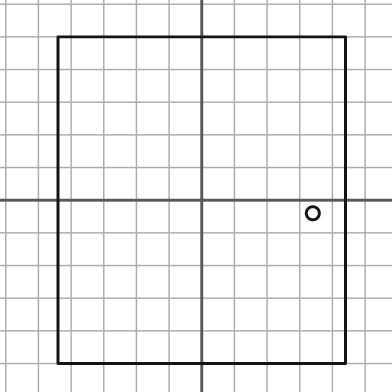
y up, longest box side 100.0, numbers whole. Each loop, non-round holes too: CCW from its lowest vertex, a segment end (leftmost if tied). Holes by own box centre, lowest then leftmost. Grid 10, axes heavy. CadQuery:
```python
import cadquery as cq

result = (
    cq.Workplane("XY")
    .moveTo(-44.0, -50.0)
    .lineTo(44.0, -50.0)
    .lineTo(44.0, 50.0)
    .lineTo(-44.0, 50.0)
    .close()
    .moveTo(34.0, -4.0)
    .circle(2.0)
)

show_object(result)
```